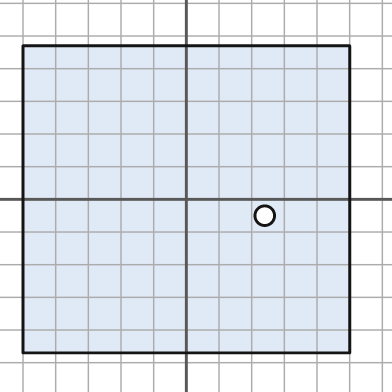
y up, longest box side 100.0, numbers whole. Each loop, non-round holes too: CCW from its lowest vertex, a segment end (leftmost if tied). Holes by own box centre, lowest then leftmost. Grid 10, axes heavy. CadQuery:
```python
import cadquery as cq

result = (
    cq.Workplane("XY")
    .moveTo(-50.0, -47.0)
    .lineTo(50.0, -47.0)
    .lineTo(50.0, 47.0)
    .lineTo(-50.0, 47.0)
    .close()
    .moveTo(24.0, -5.0)
    .circle(3.0)
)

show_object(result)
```